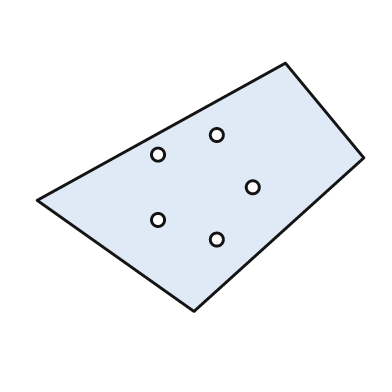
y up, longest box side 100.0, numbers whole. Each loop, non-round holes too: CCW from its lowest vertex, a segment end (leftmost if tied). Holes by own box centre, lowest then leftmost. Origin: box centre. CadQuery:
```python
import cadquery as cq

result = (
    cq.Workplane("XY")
    .moveTo(-2.0, -38.0)
    .lineTo(50.0, 9.0)
    .lineTo(26.0, 38.0)
    .lineTo(-50.0, -4.0)
    .close()
    .moveTo(5.0, -16.0)
    .circle(2.0)
    .moveTo(-13.0, -10.0)
    .circle(2.0)
    .moveTo(16.0, 0.0)
    .circle(2.0)
    .moveTo(-13.0, 10.0)
    .circle(2.0)
    .moveTo(5.0, 16.0)
    .circle(2.0)
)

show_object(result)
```